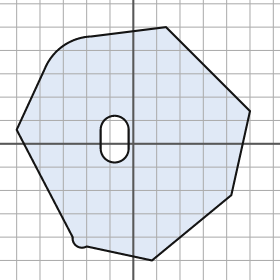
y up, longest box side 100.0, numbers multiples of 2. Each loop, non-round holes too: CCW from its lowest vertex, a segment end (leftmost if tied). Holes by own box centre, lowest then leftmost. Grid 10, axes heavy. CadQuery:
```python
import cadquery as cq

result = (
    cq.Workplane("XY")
    .moveTo(8.0, -50.0)
    .lineTo(42.0, -22.0)
    .lineTo(50.0, 14.0)
    .lineTo(14.0, 50.0)
    .lineTo(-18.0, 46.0)
    .threePointArc((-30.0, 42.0), (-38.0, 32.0))
    .lineTo(-50.0, 6.0)
    .lineTo(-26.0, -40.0)
    .threePointArc((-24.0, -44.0), (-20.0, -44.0))
    .close()
    .moveTo(-14.0, -2.0)
    .threePointArc((-8.0, -8.0), (-2.0, -2.0))
    .lineTo(-2.0, 6.0)
    .threePointArc((-8.0, 12.0), (-14.0, 6.0))
    .close()
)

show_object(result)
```